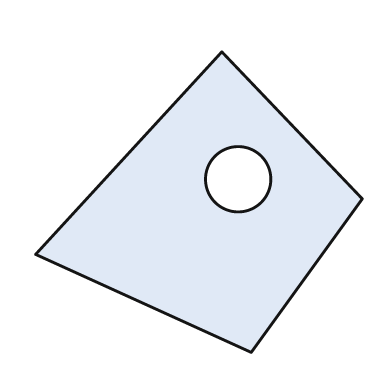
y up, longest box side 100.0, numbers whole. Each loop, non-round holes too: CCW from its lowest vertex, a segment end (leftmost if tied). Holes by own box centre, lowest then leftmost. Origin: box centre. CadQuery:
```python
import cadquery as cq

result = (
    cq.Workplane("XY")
    .moveTo(16.0, -46.0)
    .lineTo(50.0, 1.0)
    .lineTo(7.0, 46.0)
    .lineTo(-50.0, -16.0)
    .close()
    .moveTo(12.0, 7.0)
    .circle(10.0)
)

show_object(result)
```